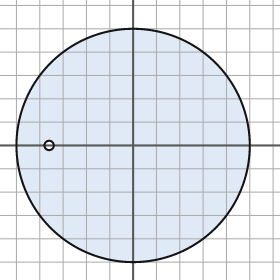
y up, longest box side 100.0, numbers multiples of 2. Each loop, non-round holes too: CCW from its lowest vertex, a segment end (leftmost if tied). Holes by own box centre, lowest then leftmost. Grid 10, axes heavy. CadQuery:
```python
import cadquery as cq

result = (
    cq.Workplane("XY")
    .moveTo(0.0, 0.0)
    .circle(50.0)
    .moveTo(-36.0, 0.0)
    .circle(2.0)
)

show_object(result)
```